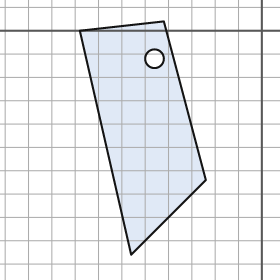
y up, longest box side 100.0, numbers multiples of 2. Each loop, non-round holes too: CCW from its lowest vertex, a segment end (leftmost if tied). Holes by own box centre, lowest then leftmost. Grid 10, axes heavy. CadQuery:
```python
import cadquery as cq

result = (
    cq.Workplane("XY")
    .moveTo(-56.0, -96.0)
    .lineTo(-24.0, -64.0)
    .lineTo(-42.0, 4.0)
    .lineTo(-78.0, 0.0)
    .close()
    .moveTo(-46.0, -12.0)
    .circle(4.0)
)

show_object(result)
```